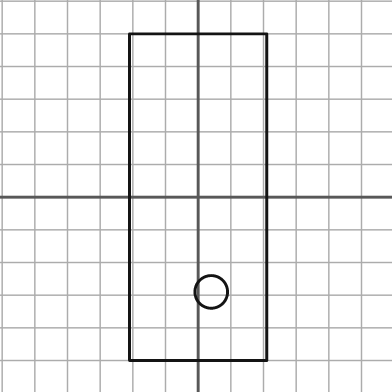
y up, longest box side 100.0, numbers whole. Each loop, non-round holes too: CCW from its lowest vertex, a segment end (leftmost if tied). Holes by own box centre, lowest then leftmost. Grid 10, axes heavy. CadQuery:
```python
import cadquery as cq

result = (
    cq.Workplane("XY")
    .moveTo(-21.0, -50.0)
    .lineTo(21.0, -50.0)
    .lineTo(21.0, 50.0)
    .lineTo(-21.0, 50.0)
    .close()
    .moveTo(4.0, -29.0)
    .circle(5.0)
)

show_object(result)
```